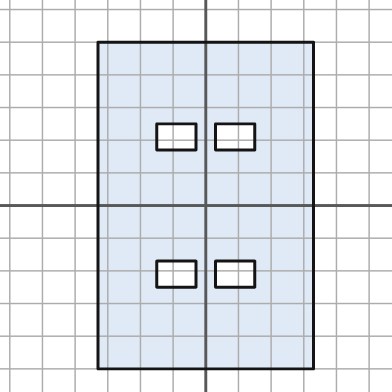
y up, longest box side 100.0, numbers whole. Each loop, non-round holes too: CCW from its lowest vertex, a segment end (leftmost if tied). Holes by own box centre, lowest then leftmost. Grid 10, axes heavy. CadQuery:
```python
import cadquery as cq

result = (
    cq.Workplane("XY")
    .moveTo(-33.0, -50.0)
    .lineTo(33.0, -50.0)
    .lineTo(33.0, 50.0)
    .lineTo(-33.0, 50.0)
    .close()
    .moveTo(-15.0, -25.0)
    .lineTo(-3.0, -25.0)
    .lineTo(-3.0, -17.0)
    .lineTo(-15.0, -17.0)
    .close()
    .moveTo(3.0, -25.0)
    .lineTo(15.0, -25.0)
    .lineTo(15.0, -17.0)
    .lineTo(3.0, -17.0)
    .close()
    .moveTo(-15.0, 17.0)
    .lineTo(-3.0, 17.0)
    .lineTo(-3.0, 25.0)
    .lineTo(-15.0, 25.0)
    .close()
    .moveTo(3.0, 17.0)
    .lineTo(15.0, 17.0)
    .lineTo(15.0, 25.0)
    .lineTo(3.0, 25.0)
    .close()
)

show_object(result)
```